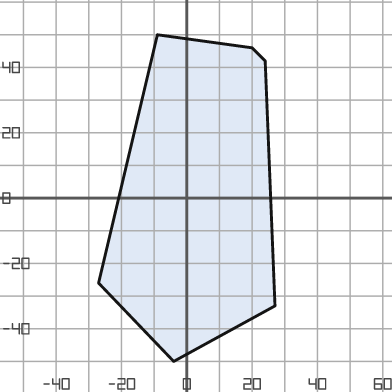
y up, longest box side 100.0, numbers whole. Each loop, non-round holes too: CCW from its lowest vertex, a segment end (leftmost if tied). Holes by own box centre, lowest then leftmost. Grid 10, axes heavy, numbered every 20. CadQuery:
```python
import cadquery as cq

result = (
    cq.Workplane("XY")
    .moveTo(-4.0, -50.0)
    .lineTo(27.0, -33.0)
    .lineTo(24.0, 42.0)
    .lineTo(20.0, 46.0)
    .lineTo(-9.0, 50.0)
    .lineTo(-27.0, -26.0)
    .close()
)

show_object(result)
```